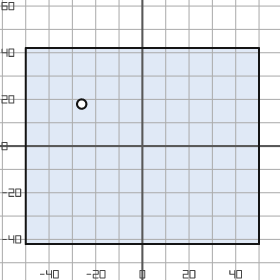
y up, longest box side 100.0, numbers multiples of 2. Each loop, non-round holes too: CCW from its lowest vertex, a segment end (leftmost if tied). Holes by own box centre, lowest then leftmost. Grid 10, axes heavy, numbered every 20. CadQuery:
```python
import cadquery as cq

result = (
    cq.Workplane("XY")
    .moveTo(-50.0, -42.0)
    .lineTo(50.0, -42.0)
    .lineTo(50.0, 42.0)
    .lineTo(-50.0, 42.0)
    .close()
    .moveTo(-26.0, 18.0)
    .circle(2.0)
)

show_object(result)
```